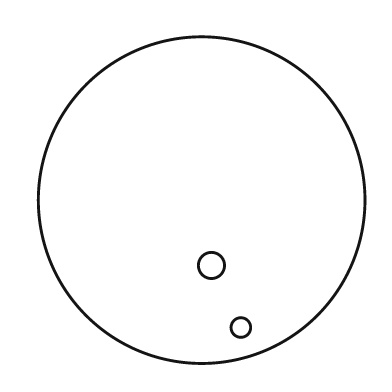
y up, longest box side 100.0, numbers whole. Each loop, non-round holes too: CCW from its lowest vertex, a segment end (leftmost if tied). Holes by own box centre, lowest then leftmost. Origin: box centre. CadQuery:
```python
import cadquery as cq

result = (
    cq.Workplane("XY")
    .moveTo(0.0, 0.0)
    .circle(50.0)
    .moveTo(12.0, -39.0)
    .circle(3.0)
    .moveTo(3.0, -20.0)
    .circle(4.0)
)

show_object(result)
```